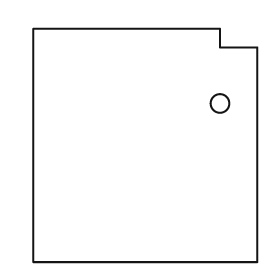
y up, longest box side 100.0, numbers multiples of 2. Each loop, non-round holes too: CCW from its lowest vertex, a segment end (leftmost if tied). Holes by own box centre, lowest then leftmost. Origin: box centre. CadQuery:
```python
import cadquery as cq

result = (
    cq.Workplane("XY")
    .moveTo(-48.0, -50.0)
    .lineTo(48.0, -50.0)
    .lineTo(48.0, 42.0)
    .lineTo(32.0, 42.0)
    .lineTo(32.0, 50.0)
    .lineTo(-48.0, 50.0)
    .close()
    .moveTo(32.0, 18.0)
    .circle(4.0)
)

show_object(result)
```